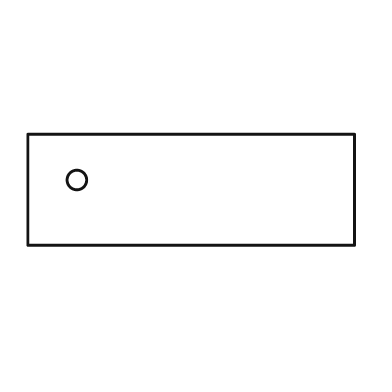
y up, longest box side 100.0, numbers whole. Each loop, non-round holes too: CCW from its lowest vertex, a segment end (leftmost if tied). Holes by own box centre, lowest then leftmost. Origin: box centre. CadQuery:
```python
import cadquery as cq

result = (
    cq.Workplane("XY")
    .moveTo(-50.0, -17.0)
    .lineTo(50.0, -17.0)
    .lineTo(50.0, 17.0)
    .lineTo(-50.0, 17.0)
    .close()
    .moveTo(-35.0, 3.0)
    .circle(3.0)
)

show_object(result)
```